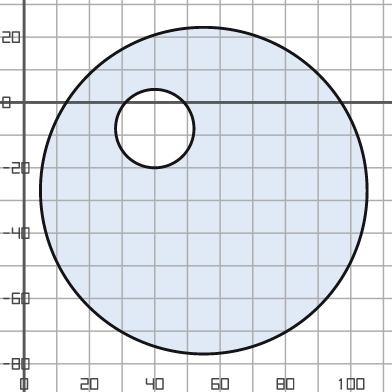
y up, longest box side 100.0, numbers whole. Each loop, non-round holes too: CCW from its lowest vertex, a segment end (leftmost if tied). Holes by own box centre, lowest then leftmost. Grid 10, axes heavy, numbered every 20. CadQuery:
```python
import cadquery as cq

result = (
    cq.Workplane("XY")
    .moveTo(55.0, -27.0)
    .circle(50.0)
    .moveTo(40.0, -8.0)
    .circle(12.0)
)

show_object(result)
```